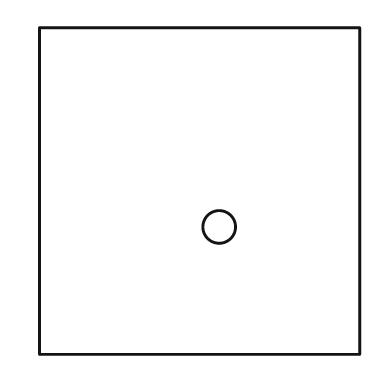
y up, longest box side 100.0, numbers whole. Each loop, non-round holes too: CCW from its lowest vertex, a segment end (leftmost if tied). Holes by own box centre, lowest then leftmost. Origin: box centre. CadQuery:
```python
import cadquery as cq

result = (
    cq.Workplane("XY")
    .moveTo(-49.0, -50.0)
    .lineTo(49.0, -50.0)
    .lineTo(49.0, 50.0)
    .lineTo(-49.0, 50.0)
    .close()
    .moveTo(6.0, -11.0)
    .circle(5.0)
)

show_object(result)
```